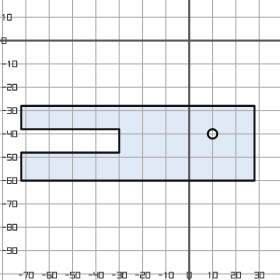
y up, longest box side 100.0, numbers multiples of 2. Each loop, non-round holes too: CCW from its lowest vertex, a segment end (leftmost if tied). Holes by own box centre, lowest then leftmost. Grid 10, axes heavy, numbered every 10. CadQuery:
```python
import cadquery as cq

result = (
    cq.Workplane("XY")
    .moveTo(-72.0, -60.0)
    .lineTo(28.0, -60.0)
    .lineTo(28.0, -28.0)
    .lineTo(-72.0, -28.0)
    .lineTo(-72.0, -38.0)
    .lineTo(-30.0, -38.0)
    .lineTo(-30.0, -48.0)
    .lineTo(-72.0, -48.0)
    .close()
    .moveTo(10.0, -40.0)
    .circle(2.0)
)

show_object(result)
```